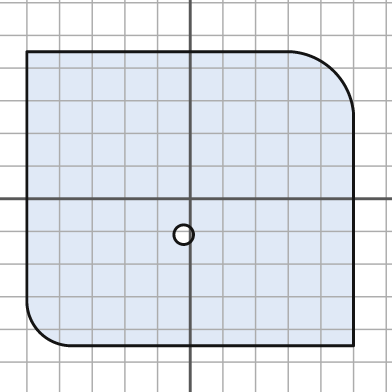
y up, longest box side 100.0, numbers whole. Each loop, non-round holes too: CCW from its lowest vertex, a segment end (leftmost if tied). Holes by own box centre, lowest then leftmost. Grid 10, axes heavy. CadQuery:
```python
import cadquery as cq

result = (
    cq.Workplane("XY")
    .moveTo(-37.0, -45.0)
    .lineTo(50.0, -45.0)
    .lineTo(50.0, 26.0)
    .threePointArc((44.0, 39.0), (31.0, 45.0))
    .lineTo(-50.0, 45.0)
    .lineTo(-50.0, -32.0)
    .threePointArc((-46.0, -41.0), (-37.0, -45.0))
    .close()
    .moveTo(-2.0, -11.0)
    .circle(3.0)
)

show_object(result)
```